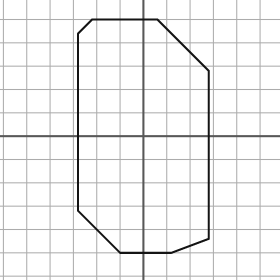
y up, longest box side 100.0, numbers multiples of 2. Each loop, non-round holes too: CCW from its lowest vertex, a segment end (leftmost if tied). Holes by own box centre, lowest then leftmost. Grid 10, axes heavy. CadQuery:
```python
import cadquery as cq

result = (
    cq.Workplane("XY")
    .moveTo(-10.0, -50.0)
    .lineTo(12.0, -50.0)
    .lineTo(28.0, -44.0)
    .lineTo(28.0, 28.0)
    .lineTo(6.0, 50.0)
    .lineTo(-22.0, 50.0)
    .lineTo(-28.0, 44.0)
    .lineTo(-28.0, -32.0)
    .close()
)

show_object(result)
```